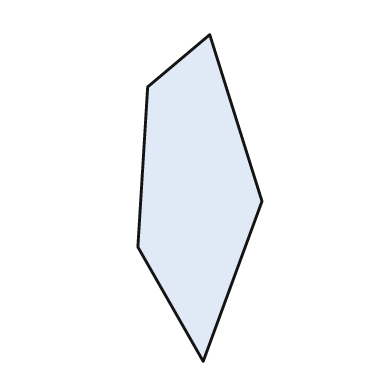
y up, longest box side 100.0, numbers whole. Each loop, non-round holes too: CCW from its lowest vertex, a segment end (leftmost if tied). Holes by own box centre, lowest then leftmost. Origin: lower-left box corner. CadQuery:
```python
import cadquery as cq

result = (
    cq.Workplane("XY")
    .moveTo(20.0, 0.0)
    .lineTo(38.0, 49.0)
    .lineTo(22.0, 100.0)
    .lineTo(3.0, 84.0)
    .lineTo(0.0, 35.0)
    .close()
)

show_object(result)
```